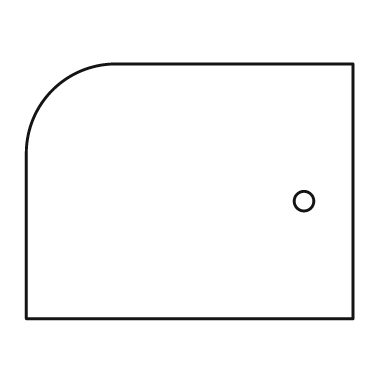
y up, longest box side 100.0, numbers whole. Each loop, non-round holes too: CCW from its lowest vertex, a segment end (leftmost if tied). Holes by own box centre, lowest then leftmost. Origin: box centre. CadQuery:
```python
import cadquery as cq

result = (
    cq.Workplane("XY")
    .moveTo(-50.0, -39.0)
    .lineTo(50.0, -39.0)
    .lineTo(50.0, 39.0)
    .lineTo(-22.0, 39.0)
    .threePointArc((-42.0, 31.0), (-50.0, 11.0))
    .close()
    .moveTo(35.0, -3.0)
    .circle(3.0)
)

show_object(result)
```